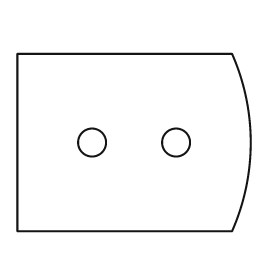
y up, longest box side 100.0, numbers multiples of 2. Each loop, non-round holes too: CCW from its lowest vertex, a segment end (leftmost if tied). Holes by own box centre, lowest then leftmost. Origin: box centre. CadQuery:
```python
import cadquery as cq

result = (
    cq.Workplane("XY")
    .moveTo(-50.0, -38.0)
    .lineTo(42.0, -38.0)
    .threePointArc((50.0, 0.0), (42.0, 38.0))
    .lineTo(-50.0, 38.0)
    .close()
    .moveTo(-18.0, 0.0)
    .circle(6.0)
    .moveTo(18.0, 0.0)
    .circle(6.0)
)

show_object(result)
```